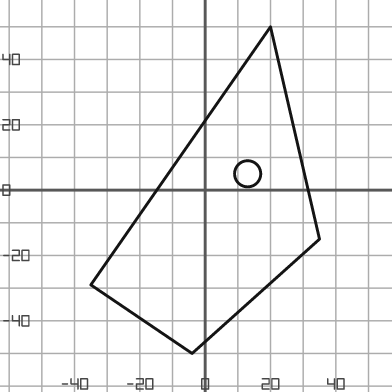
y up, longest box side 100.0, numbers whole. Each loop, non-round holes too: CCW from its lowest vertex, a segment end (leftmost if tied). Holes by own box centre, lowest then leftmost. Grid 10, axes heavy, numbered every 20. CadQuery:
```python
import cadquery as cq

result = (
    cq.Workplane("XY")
    .moveTo(-4.0, -50.0)
    .lineTo(35.0, -15.0)
    .lineTo(20.0, 50.0)
    .lineTo(-35.0, -29.0)
    .close()
    .moveTo(13.0, 5.0)
    .circle(4.0)
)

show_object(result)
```